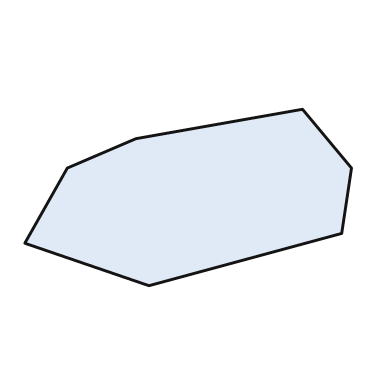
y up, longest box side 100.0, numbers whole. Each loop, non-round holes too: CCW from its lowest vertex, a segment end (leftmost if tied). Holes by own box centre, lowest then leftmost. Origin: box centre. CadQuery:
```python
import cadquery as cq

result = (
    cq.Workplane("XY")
    .moveTo(-12.0, -27.0)
    .lineTo(47.0, -11.0)
    .lineTo(50.0, 9.0)
    .lineTo(35.0, 27.0)
    .lineTo(-16.0, 18.0)
    .lineTo(-37.0, 9.0)
    .lineTo(-50.0, -14.0)
    .close()
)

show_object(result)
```